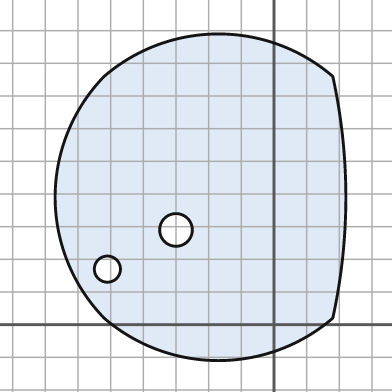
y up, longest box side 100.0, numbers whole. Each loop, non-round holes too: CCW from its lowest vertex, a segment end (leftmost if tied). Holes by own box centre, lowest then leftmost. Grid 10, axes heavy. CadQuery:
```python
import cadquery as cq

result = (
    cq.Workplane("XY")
    .moveTo(-52.0, 2.0)
    .threePointArc((-17.0, -11.0), (18.0, 2.0))
    .threePointArc((22.0, 39.0), (18.0, 76.0))
    .threePointArc((-17.0, 89.0), (-52.0, 76.0))
    .threePointArc((-67.0, 39.0), (-52.0, 2.0))
    .close()
    .moveTo(-51.0, 17.0)
    .circle(4.0)
    .moveTo(-30.0, 29.0)
    .circle(5.0)
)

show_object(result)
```